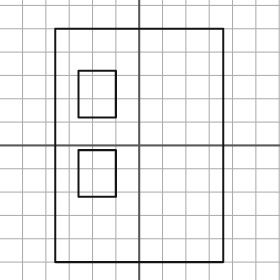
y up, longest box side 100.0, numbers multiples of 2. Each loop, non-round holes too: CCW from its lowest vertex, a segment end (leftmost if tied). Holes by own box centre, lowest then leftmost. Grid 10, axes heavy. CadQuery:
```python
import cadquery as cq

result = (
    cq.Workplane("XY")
    .moveTo(-36.0, -50.0)
    .lineTo(36.0, -50.0)
    .lineTo(36.0, 50.0)
    .lineTo(-36.0, 50.0)
    .close()
    .moveTo(-26.0, -22.0)
    .lineTo(-10.0, -22.0)
    .lineTo(-10.0, -2.0)
    .lineTo(-26.0, -2.0)
    .close()
    .moveTo(-26.0, 12.0)
    .lineTo(-10.0, 12.0)
    .lineTo(-10.0, 32.0)
    .lineTo(-26.0, 32.0)
    .close()
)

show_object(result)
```